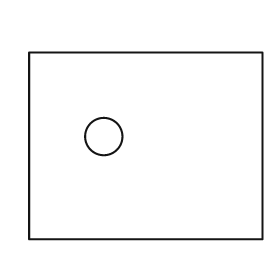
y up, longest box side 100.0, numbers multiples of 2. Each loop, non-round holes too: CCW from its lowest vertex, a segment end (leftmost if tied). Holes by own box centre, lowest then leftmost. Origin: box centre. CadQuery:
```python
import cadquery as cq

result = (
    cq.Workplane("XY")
    .moveTo(-50.0, -40.0)
    .lineTo(50.0, -40.0)
    .lineTo(50.0, 40.0)
    .lineTo(-50.0, 40.0)
    .close()
    .moveTo(-18.0, 4.0)
    .circle(8.0)
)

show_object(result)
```